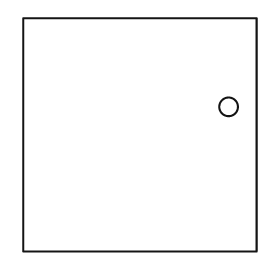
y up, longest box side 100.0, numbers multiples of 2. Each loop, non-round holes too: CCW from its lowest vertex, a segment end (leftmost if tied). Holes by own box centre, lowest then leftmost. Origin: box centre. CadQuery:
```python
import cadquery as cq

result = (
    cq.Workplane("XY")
    .moveTo(-50.0, -50.0)
    .lineTo(50.0, -50.0)
    .lineTo(50.0, 50.0)
    .lineTo(-50.0, 50.0)
    .close()
    .moveTo(38.0, 12.0)
    .circle(4.0)
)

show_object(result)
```